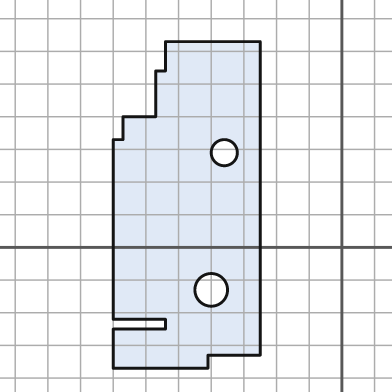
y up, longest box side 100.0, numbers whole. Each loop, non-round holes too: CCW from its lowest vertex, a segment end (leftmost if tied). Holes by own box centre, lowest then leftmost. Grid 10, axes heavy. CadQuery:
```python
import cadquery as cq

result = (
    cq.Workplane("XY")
    .moveTo(-70.0, -37.0)
    .lineTo(-41.0, -37.0)
    .lineTo(-41.0, -33.0)
    .lineTo(-25.0, -33.0)
    .lineTo(-25.0, 63.0)
    .lineTo(-54.0, 63.0)
    .lineTo(-54.0, 54.0)
    .lineTo(-57.0, 54.0)
    .lineTo(-57.0, 40.0)
    .lineTo(-67.0, 40.0)
    .lineTo(-67.0, 33.0)
    .lineTo(-70.0, 33.0)
    .lineTo(-70.0, -22.0)
    .lineTo(-54.0, -22.0)
    .lineTo(-54.0, -25.0)
    .lineTo(-70.0, -25.0)
    .close()
    .moveTo(-40.0, -13.0)
    .circle(5.0)
    .moveTo(-36.0, 29.0)
    .circle(4.0)
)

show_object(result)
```